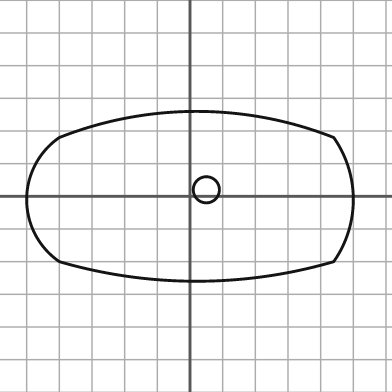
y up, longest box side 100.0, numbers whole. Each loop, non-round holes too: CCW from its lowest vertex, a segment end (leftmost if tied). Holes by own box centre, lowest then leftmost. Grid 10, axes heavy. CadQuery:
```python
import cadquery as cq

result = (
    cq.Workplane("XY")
    .moveTo(-40.0, -20.0)
    .threePointArc((2.0, -26.0), (44.0, -20.0))
    .threePointArc((50.0, -1.0), (44.0, 18.0))
    .threePointArc((2.0, 26.0), (-40.0, 18.0))
    .threePointArc((-50.0, -1.0), (-40.0, -20.0))
    .close()
    .moveTo(5.0, 2.0)
    .circle(4.0)
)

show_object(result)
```